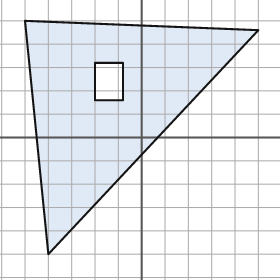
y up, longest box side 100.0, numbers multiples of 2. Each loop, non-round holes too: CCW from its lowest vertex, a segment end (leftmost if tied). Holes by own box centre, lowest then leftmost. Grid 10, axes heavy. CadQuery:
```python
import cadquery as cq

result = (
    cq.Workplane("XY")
    .moveTo(-40.0, -50.0)
    .lineTo(50.0, 46.0)
    .lineTo(-50.0, 50.0)
    .close()
    .moveTo(-20.0, 16.0)
    .lineTo(-8.0, 16.0)
    .lineTo(-8.0, 32.0)
    .lineTo(-20.0, 32.0)
    .close()
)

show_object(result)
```